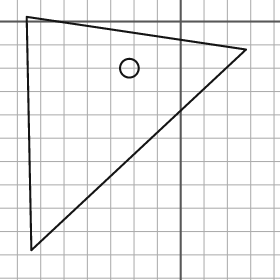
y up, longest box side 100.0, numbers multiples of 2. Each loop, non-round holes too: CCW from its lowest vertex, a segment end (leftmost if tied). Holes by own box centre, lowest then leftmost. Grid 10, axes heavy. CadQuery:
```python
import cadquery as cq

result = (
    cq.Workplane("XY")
    .moveTo(-64.0, -98.0)
    .lineTo(28.0, -12.0)
    .lineTo(-66.0, 2.0)
    .close()
    .moveTo(-22.0, -20.0)
    .circle(4.0)
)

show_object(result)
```